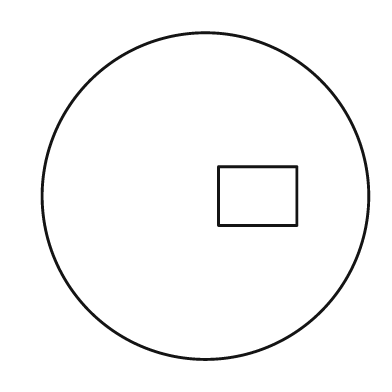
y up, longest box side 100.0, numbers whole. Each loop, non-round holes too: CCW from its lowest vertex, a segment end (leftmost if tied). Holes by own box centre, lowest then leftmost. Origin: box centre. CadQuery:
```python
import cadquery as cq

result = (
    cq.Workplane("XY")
    .moveTo(0.0, 0.0)
    .circle(50.0)
    .moveTo(4.0, -9.0)
    .lineTo(28.0, -9.0)
    .lineTo(28.0, 9.0)
    .lineTo(4.0, 9.0)
    .close()
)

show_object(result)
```